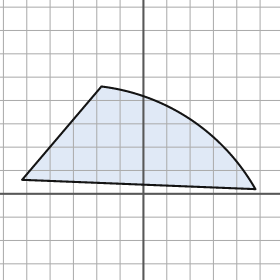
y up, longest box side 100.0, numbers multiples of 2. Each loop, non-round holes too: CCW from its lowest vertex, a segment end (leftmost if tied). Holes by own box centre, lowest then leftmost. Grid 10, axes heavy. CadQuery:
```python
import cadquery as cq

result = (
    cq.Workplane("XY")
    .moveTo(48.0, 2.0)
    .threePointArc((20.0, 32.0), (-18.0, 46.0))
    .lineTo(-52.0, 6.0)
    .close()
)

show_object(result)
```